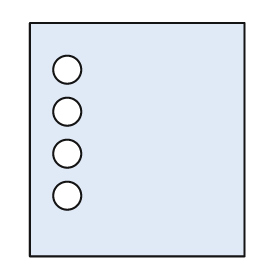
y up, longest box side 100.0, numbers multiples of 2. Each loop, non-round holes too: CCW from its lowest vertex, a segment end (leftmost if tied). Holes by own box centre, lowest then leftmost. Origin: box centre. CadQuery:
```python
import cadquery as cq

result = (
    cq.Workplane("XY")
    .moveTo(-46.0, -50.0)
    .lineTo(46.0, -50.0)
    .lineTo(46.0, 50.0)
    .lineTo(-46.0, 50.0)
    .close()
    .moveTo(-30.0, -24.0)
    .circle(6.0)
    .moveTo(-30.0, -6.0)
    .circle(6.0)
    .moveTo(-30.0, 12.0)
    .circle(6.0)
    .moveTo(-30.0, 30.0)
    .circle(6.0)
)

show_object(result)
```